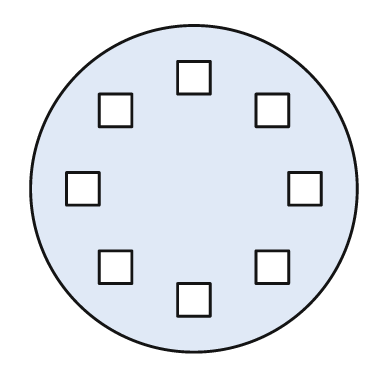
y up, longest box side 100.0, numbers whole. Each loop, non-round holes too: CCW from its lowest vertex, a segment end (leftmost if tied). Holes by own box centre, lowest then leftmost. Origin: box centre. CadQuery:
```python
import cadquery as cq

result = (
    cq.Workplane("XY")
    .moveTo(0.0, 0.0)
    .circle(50.0)
    .moveTo(-5.0, -39.0)
    .lineTo(5.0, -39.0)
    .lineTo(5.0, -29.0)
    .lineTo(-5.0, -29.0)
    .close()
    .moveTo(-29.0, -29.0)
    .lineTo(-19.0, -29.0)
    .lineTo(-19.0, -19.0)
    .lineTo(-29.0, -19.0)
    .close()
    .moveTo(19.0, -29.0)
    .lineTo(29.0, -29.0)
    .lineTo(29.0, -19.0)
    .lineTo(19.0, -19.0)
    .close()
    .moveTo(-39.0, -5.0)
    .lineTo(-29.0, -5.0)
    .lineTo(-29.0, 5.0)
    .lineTo(-39.0, 5.0)
    .close()
    .moveTo(29.0, -5.0)
    .lineTo(39.0, -5.0)
    .lineTo(39.0, 5.0)
    .lineTo(29.0, 5.0)
    .close()
    .moveTo(-29.0, 19.0)
    .lineTo(-19.0, 19.0)
    .lineTo(-19.0, 29.0)
    .lineTo(-29.0, 29.0)
    .close()
    .moveTo(19.0, 19.0)
    .lineTo(29.0, 19.0)
    .lineTo(29.0, 29.0)
    .lineTo(19.0, 29.0)
    .close()
    .moveTo(-5.0, 29.0)
    .lineTo(5.0, 29.0)
    .lineTo(5.0, 39.0)
    .lineTo(-5.0, 39.0)
    .close()
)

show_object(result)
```